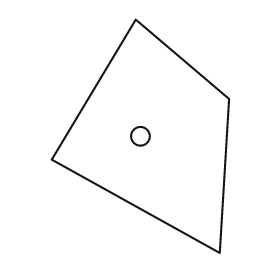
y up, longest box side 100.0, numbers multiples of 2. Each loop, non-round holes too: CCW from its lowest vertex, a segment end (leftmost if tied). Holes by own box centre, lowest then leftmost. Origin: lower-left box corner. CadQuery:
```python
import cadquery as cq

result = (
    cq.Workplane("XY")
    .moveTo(72.0, 0.0)
    .lineTo(76.0, 66.0)
    .lineTo(36.0, 100.0)
    .lineTo(0.0, 40.0)
    .close()
    .moveTo(38.0, 50.0)
    .circle(4.0)
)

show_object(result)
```